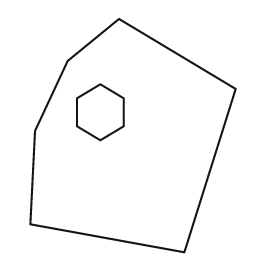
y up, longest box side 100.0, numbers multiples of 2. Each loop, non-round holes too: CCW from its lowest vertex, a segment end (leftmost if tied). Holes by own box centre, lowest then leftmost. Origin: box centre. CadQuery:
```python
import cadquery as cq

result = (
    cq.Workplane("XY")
    .moveTo(22.0, -50.0)
    .lineTo(44.0, 20.0)
    .lineTo(-6.0, 50.0)
    .lineTo(-28.0, 32.0)
    .lineTo(-42.0, 2.0)
    .lineTo(-44.0, -38.0)
    .close()
    .moveTo(-14.0, -2.0)
    .lineTo(-4.0, 4.0)
    .lineTo(-4.0, 16.0)
    .lineTo(-14.0, 22.0)
    .lineTo(-24.0, 16.0)
    .lineTo(-24.0, 4.0)
    .close()
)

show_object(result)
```